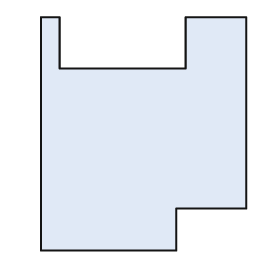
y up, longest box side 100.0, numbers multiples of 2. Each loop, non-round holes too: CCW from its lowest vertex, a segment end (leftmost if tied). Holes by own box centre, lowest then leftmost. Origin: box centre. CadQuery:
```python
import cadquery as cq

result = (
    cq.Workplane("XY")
    .moveTo(-44.0, -50.0)
    .lineTo(14.0, -50.0)
    .lineTo(14.0, -32.0)
    .lineTo(44.0, -32.0)
    .lineTo(44.0, 50.0)
    .lineTo(18.0, 50.0)
    .lineTo(18.0, 28.0)
    .lineTo(-36.0, 28.0)
    .lineTo(-36.0, 50.0)
    .lineTo(-44.0, 50.0)
    .close()
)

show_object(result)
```